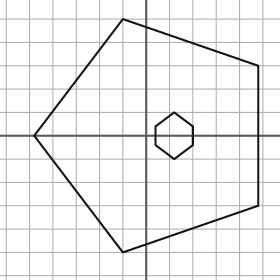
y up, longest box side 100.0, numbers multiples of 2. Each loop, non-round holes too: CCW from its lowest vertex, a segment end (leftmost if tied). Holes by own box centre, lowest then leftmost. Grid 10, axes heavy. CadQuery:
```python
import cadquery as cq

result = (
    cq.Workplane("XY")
    .moveTo(-10.0, -50.0)
    .lineTo(48.0, -30.0)
    .lineTo(48.0, 30.0)
    .lineTo(-10.0, 50.0)
    .lineTo(-48.0, 0.0)
    .close()
    .moveTo(12.0, -10.0)
    .lineTo(20.0, -4.0)
    .lineTo(20.0, 4.0)
    .lineTo(12.0, 10.0)
    .lineTo(4.0, 4.0)
    .lineTo(4.0, -4.0)
    .close()
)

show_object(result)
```